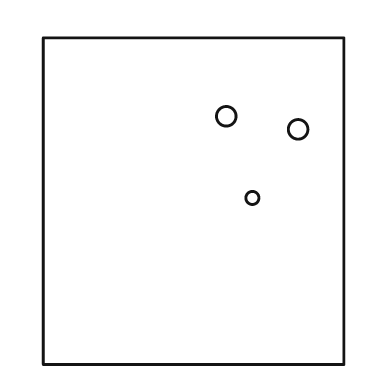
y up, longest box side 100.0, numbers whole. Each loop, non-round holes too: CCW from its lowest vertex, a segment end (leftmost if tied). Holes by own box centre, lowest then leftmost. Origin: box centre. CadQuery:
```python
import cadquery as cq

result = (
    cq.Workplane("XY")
    .moveTo(-46.0, -50.0)
    .lineTo(46.0, -50.0)
    .lineTo(46.0, 50.0)
    .lineTo(-46.0, 50.0)
    .close()
    .moveTo(18.0, 1.0)
    .circle(2.0)
    .moveTo(32.0, 22.0)
    .circle(3.0)
    .moveTo(10.0, 26.0)
    .circle(3.0)
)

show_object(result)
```